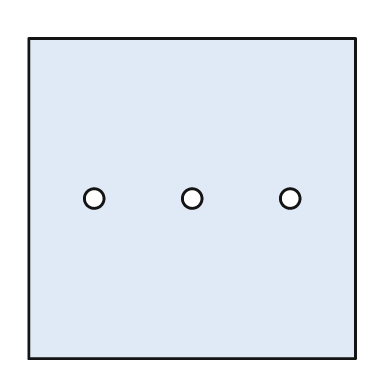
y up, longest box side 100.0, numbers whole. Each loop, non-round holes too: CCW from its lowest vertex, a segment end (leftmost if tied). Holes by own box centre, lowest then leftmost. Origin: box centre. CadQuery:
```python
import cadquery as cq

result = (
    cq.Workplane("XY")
    .moveTo(-50.0, -49.0)
    .lineTo(50.0, -49.0)
    .lineTo(50.0, 49.0)
    .lineTo(-50.0, 49.0)
    .close()
    .moveTo(-30.0, 0.0)
    .circle(3.0)
    .moveTo(0.0, 0.0)
    .circle(3.0)
    .moveTo(30.0, 0.0)
    .circle(3.0)
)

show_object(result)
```